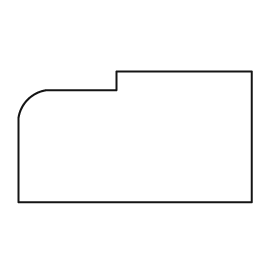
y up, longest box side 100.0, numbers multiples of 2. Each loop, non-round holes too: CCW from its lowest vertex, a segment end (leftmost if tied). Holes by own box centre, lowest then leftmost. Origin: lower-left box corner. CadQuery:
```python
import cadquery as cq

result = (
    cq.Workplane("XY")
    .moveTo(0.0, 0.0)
    .lineTo(100.0, 0.0)
    .lineTo(100.0, 56.0)
    .lineTo(42.0, 56.0)
    .lineTo(42.0, 48.0)
    .lineTo(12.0, 48.0)
    .threePointArc((4.0, 44.0), (0.0, 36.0))
    .close()
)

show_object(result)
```